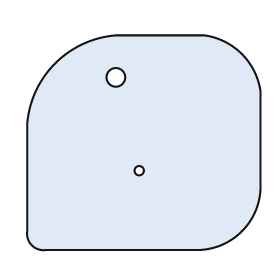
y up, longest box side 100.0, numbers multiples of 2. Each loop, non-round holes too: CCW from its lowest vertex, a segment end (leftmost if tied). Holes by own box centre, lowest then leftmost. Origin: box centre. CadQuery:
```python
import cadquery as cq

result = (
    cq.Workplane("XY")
    .moveTo(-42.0, -46.0)
    .lineTo(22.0, -46.0)
    .threePointArc((42.0, -38.0), (50.0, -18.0))
    .lineTo(50.0, 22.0)
    .threePointArc((42.0, 38.0), (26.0, 46.0))
    .lineTo(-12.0, 46.0)
    .threePointArc((-38.0, 34.0), (-50.0, 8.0))
    .lineTo(-50.0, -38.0)
    .threePointArc((-48.0, -44.0), (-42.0, -46.0))
    .close()
    .moveTo(-2.0, -12.0)
    .circle(2.0)
    .moveTo(-12.0, 28.0)
    .circle(4.0)
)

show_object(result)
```